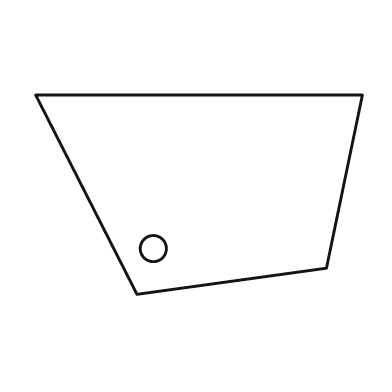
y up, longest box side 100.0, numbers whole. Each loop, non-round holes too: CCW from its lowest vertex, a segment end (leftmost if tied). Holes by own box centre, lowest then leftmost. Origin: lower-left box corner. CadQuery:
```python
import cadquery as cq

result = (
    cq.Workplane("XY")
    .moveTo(31.0, 0.0)
    .lineTo(89.0, 8.0)
    .lineTo(100.0, 61.0)
    .lineTo(0.0, 61.0)
    .close()
    .moveTo(36.0, 14.0)
    .circle(4.0)
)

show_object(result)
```